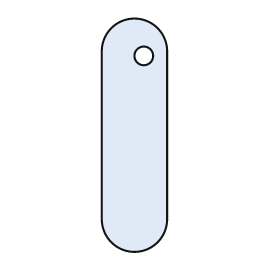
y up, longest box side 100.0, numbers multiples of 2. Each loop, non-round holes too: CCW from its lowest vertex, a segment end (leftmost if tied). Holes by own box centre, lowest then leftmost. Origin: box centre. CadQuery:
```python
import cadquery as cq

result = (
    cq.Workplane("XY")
    .moveTo(-14.0, -36.0)
    .threePointArc((0.0, -50.0), (14.0, -36.0))
    .lineTo(14.0, 36.0)
    .threePointArc((0.0, 50.0), (-14.0, 36.0))
    .close()
    .moveTo(4.0, 34.0)
    .circle(4.0)
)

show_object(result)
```